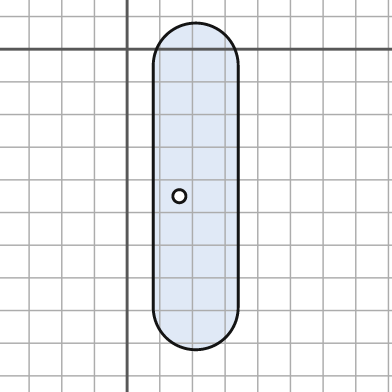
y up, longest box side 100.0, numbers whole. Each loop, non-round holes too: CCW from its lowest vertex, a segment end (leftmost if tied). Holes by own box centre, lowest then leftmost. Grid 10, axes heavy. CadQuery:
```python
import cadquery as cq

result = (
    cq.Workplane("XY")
    .moveTo(8.0, -79.0)
    .threePointArc((21.0, -92.0), (34.0, -79.0))
    .lineTo(34.0, -5.0)
    .threePointArc((21.0, 8.0), (8.0, -5.0))
    .close()
    .moveTo(16.0, -45.0)
    .circle(2.0)
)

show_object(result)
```